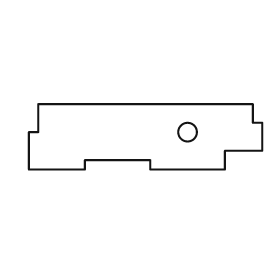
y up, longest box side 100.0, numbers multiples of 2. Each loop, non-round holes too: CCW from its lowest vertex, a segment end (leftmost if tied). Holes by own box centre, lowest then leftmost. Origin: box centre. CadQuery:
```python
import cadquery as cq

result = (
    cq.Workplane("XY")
    .moveTo(-50.0, -14.0)
    .lineTo(-26.0, -14.0)
    .lineTo(-26.0, -10.0)
    .lineTo(2.0, -10.0)
    .lineTo(2.0, -14.0)
    .lineTo(34.0, -14.0)
    .lineTo(34.0, -6.0)
    .lineTo(50.0, -6.0)
    .lineTo(50.0, 6.0)
    .lineTo(46.0, 6.0)
    .lineTo(46.0, 14.0)
    .lineTo(-46.0, 14.0)
    .lineTo(-46.0, 2.0)
    .lineTo(-50.0, 2.0)
    .close()
    .moveTo(18.0, 2.0)
    .circle(4.0)
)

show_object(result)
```